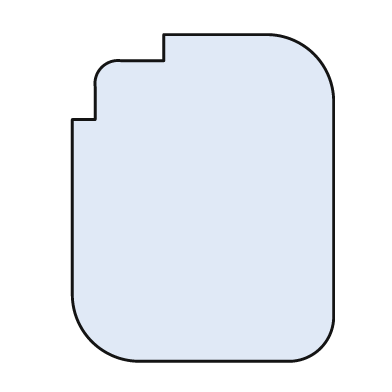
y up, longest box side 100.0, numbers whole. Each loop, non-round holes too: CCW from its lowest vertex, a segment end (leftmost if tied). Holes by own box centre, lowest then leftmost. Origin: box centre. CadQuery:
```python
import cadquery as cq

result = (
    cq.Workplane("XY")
    .moveTo(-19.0, -50.0)
    .lineTo(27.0, -50.0)
    .threePointArc((36.0, -46.0), (40.0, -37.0))
    .lineTo(40.0, 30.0)
    .threePointArc((34.0, 44.0), (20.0, 50.0))
    .lineTo(-12.0, 50.0)
    .lineTo(-12.0, 42.0)
    .lineTo(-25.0, 42.0)
    .threePointArc((-31.0, 40.0), (-33.0, 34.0))
    .lineTo(-33.0, 24.0)
    .lineTo(-40.0, 24.0)
    .lineTo(-40.0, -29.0)
    .threePointArc((-34.0, -44.0), (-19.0, -50.0))
    .close()
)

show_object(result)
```